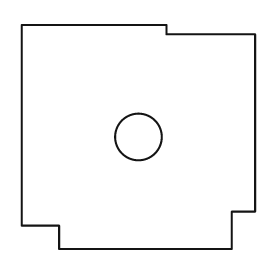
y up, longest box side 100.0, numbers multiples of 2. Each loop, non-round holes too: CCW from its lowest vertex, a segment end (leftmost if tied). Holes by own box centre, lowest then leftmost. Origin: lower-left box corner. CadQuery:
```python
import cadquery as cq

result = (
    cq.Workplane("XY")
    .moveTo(16.0, 0.0)
    .lineTo(90.0, 0.0)
    .lineTo(90.0, 16.0)
    .lineTo(100.0, 16.0)
    .lineTo(100.0, 92.0)
    .lineTo(62.0, 92.0)
    .lineTo(62.0, 96.0)
    .lineTo(0.0, 96.0)
    .lineTo(0.0, 10.0)
    .lineTo(16.0, 10.0)
    .close()
    .moveTo(50.0, 48.0)
    .circle(10.0)
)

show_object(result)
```